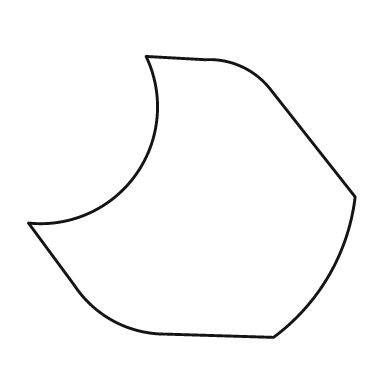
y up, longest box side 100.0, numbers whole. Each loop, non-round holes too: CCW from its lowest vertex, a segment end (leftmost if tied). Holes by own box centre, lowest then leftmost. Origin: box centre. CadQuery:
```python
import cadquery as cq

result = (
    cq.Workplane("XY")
    .moveTo(25.0, -43.0)
    .threePointArc((42.0, -24.0), (50.0, 0.0))
    .lineTo(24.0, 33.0)
    .threePointArc((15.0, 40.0), (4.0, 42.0))
    .lineTo(-14.0, 43.0)
    .threePointArc((-17.0, 7.0), (-50.0, -8.0))
    .lineTo(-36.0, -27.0)
    .threePointArc((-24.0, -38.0), (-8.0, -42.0))
    .close()
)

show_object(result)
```